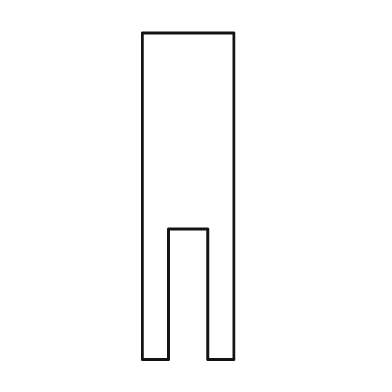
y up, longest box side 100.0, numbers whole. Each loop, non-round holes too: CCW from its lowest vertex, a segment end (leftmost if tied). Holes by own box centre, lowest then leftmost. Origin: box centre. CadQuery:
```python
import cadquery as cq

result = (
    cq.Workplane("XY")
    .moveTo(-14.0, -50.0)
    .lineTo(-6.0, -50.0)
    .lineTo(-6.0, -10.0)
    .lineTo(6.0, -10.0)
    .lineTo(6.0, -50.0)
    .lineTo(14.0, -50.0)
    .lineTo(14.0, 50.0)
    .lineTo(-14.0, 50.0)
    .close()
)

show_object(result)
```